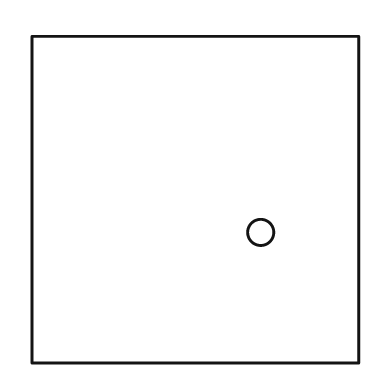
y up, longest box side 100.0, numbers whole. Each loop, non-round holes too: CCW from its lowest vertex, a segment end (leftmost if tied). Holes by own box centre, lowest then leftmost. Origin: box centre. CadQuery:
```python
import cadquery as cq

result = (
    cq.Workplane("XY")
    .moveTo(-50.0, -50.0)
    .lineTo(50.0, -50.0)
    .lineTo(50.0, 50.0)
    .lineTo(-50.0, 50.0)
    .close()
    .moveTo(20.0, -10.0)
    .circle(4.0)
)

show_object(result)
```